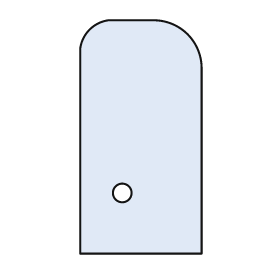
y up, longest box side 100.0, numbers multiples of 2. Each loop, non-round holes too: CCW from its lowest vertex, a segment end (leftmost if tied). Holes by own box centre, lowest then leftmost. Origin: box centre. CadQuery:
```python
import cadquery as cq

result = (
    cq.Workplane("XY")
    .moveTo(-26.0, -50.0)
    .lineTo(26.0, -50.0)
    .lineTo(26.0, 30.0)
    .threePointArc((20.0, 44.0), (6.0, 50.0))
    .lineTo(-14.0, 50.0)
    .threePointArc((-22.0, 46.0), (-26.0, 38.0))
    .close()
    .moveTo(-8.0, -24.0)
    .circle(4.0)
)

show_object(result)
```